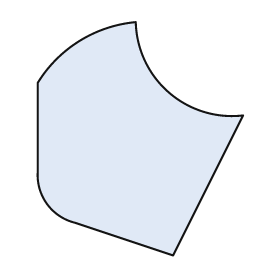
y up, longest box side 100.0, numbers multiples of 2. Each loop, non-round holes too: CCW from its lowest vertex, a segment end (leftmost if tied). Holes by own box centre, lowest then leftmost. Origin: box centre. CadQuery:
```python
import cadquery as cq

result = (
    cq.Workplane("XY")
    .moveTo(14.0, -50.0)
    .lineTo(44.0, 10.0)
    .threePointArc((12.0, 20.0), (-2.0, 50.0))
    .threePointArc((-26.0, 42.0), (-44.0, 24.0))
    .lineTo(-44.0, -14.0)
    .threePointArc((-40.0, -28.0), (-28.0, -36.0))
    .close()
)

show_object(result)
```